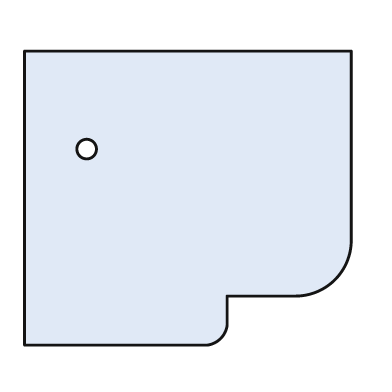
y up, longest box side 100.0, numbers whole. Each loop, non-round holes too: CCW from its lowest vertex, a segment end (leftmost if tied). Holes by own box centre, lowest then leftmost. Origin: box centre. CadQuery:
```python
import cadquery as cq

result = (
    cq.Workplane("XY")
    .moveTo(-50.0, -45.0)
    .lineTo(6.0, -45.0)
    .threePointArc((10.0, -43.0), (12.0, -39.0))
    .lineTo(12.0, -30.0)
    .lineTo(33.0, -30.0)
    .threePointArc((45.0, -25.0), (50.0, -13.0))
    .lineTo(50.0, 45.0)
    .lineTo(-50.0, 45.0)
    .close()
    .moveTo(-31.0, 15.0)
    .circle(3.0)
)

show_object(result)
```